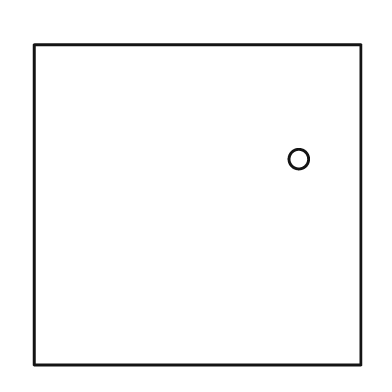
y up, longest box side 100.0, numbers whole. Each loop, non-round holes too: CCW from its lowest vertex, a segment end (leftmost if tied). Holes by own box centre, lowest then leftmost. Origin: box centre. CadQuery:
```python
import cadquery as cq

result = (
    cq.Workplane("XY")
    .moveTo(-50.0, -49.0)
    .lineTo(50.0, -49.0)
    .lineTo(50.0, 49.0)
    .lineTo(-50.0, 49.0)
    .close()
    .moveTo(31.0, 14.0)
    .circle(3.0)
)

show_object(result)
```